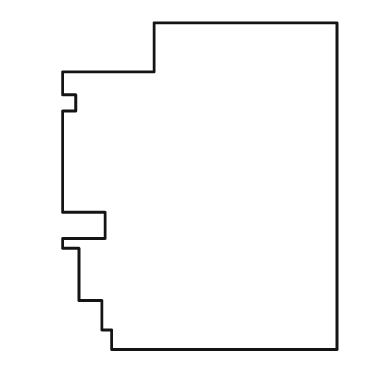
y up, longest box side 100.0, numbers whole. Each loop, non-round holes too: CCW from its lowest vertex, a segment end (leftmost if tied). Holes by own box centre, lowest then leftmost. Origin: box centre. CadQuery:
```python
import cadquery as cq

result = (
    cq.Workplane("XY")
    .moveTo(-27.0, -50.0)
    .lineTo(42.0, -50.0)
    .lineTo(42.0, 50.0)
    .lineTo(-14.0, 50.0)
    .lineTo(-14.0, 35.0)
    .lineTo(-42.0, 35.0)
    .lineTo(-42.0, 28.0)
    .lineTo(-38.0, 28.0)
    .lineTo(-38.0, 23.0)
    .lineTo(-42.0, 23.0)
    .lineTo(-42.0, -8.0)
    .lineTo(-29.0, -8.0)
    .lineTo(-29.0, -16.0)
    .lineTo(-42.0, -16.0)
    .lineTo(-42.0, -19.0)
    .lineTo(-37.0, -19.0)
    .lineTo(-37.0, -35.0)
    .lineTo(-30.0, -35.0)
    .lineTo(-30.0, -44.0)
    .lineTo(-27.0, -44.0)
    .close()
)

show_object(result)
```